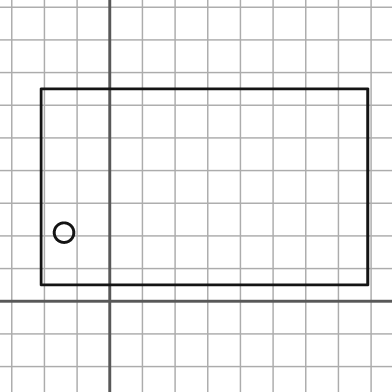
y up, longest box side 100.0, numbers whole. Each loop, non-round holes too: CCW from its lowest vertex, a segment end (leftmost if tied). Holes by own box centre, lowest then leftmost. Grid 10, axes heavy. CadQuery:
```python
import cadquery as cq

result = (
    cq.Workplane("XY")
    .moveTo(-21.0, 5.0)
    .lineTo(79.0, 5.0)
    .lineTo(79.0, 65.0)
    .lineTo(-21.0, 65.0)
    .close()
    .moveTo(-14.0, 21.0)
    .circle(3.0)
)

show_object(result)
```